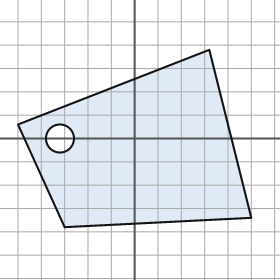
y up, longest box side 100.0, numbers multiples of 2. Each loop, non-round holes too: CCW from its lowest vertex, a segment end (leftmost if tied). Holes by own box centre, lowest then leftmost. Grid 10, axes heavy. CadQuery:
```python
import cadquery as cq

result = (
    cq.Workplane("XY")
    .moveTo(-30.0, -38.0)
    .lineTo(50.0, -34.0)
    .lineTo(32.0, 38.0)
    .lineTo(-50.0, 6.0)
    .close()
    .moveTo(-32.0, 0.0)
    .circle(6.0)
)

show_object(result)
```